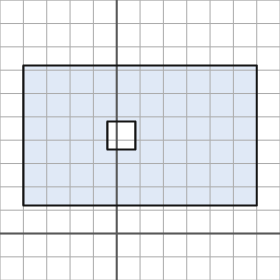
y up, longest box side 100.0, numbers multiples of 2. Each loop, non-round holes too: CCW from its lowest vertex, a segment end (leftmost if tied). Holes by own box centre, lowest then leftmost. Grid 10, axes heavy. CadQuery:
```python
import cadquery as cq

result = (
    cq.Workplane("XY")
    .moveTo(-40.0, 12.0)
    .lineTo(60.0, 12.0)
    .lineTo(60.0, 72.0)
    .lineTo(-40.0, 72.0)
    .close()
    .moveTo(-4.0, 36.0)
    .lineTo(8.0, 36.0)
    .lineTo(8.0, 48.0)
    .lineTo(-4.0, 48.0)
    .close()
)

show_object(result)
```